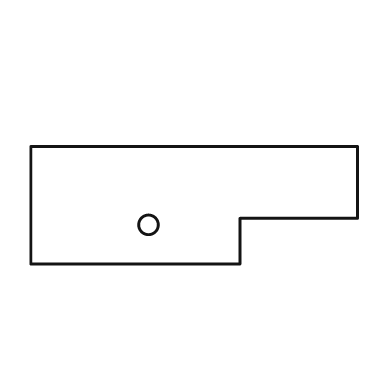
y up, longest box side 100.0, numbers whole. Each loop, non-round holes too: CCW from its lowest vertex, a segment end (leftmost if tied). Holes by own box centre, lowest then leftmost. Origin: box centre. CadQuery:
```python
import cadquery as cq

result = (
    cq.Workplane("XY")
    .moveTo(-50.0, -18.0)
    .lineTo(14.0, -18.0)
    .lineTo(14.0, -4.0)
    .lineTo(50.0, -4.0)
    .lineTo(50.0, 18.0)
    .lineTo(-50.0, 18.0)
    .close()
    .moveTo(-14.0, -6.0)
    .circle(3.0)
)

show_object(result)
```